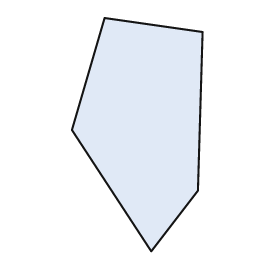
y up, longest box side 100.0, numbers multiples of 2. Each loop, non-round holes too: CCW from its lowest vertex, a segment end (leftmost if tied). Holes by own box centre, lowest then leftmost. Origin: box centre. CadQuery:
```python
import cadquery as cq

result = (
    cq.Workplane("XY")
    .moveTo(6.0, -50.0)
    .lineTo(26.0, -24.0)
    .lineTo(28.0, 44.0)
    .lineTo(-14.0, 50.0)
    .lineTo(-28.0, 2.0)
    .close()
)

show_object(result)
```